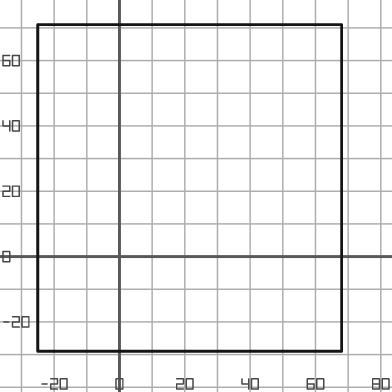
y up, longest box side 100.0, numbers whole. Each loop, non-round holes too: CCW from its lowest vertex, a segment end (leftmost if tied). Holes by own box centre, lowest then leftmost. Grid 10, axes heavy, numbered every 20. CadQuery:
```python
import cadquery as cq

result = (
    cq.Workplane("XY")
    .moveTo(-25.0, -29.0)
    .lineTo(68.0, -29.0)
    .lineTo(68.0, 71.0)
    .lineTo(-25.0, 71.0)
    .close()
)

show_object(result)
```